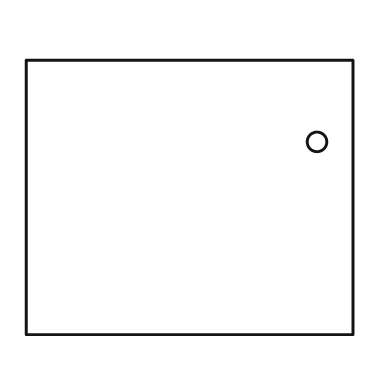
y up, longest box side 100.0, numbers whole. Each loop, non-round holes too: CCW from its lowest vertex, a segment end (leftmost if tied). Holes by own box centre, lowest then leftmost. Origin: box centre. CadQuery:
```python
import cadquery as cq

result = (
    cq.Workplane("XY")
    .moveTo(-50.0, -42.0)
    .lineTo(50.0, -42.0)
    .lineTo(50.0, 42.0)
    .lineTo(-50.0, 42.0)
    .close()
    .moveTo(39.0, 17.0)
    .circle(3.0)
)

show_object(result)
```